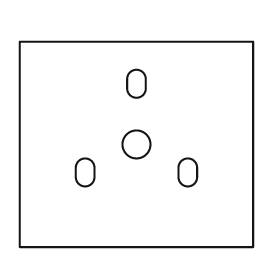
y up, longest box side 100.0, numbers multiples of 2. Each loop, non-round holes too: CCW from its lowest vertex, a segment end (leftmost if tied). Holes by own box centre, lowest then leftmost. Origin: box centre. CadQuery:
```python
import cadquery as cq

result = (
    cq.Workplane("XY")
    .moveTo(-50.0, -44.0)
    .lineTo(50.0, -44.0)
    .lineTo(50.0, 44.0)
    .lineTo(-50.0, 44.0)
    .close()
    .moveTo(-26.0, -14.0)
    .threePointArc((-22.0, -18.0), (-18.0, -14.0))
    .lineTo(-18.0, -10.0)
    .threePointArc((-22.0, -6.0), (-26.0, -10.0))
    .close()
    .moveTo(18.0, -14.0)
    .threePointArc((22.0, -18.0), (26.0, -14.0))
    .lineTo(26.0, -10.0)
    .threePointArc((22.0, -6.0), (18.0, -10.0))
    .close()
    .moveTo(0.0, 0.0)
    .circle(6.0)
    .moveTo(-4.0, 24.0)
    .threePointArc((0.0, 20.0), (4.0, 24.0))
    .lineTo(4.0, 28.0)
    .threePointArc((0.0, 32.0), (-4.0, 28.0))
    .close()
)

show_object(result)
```